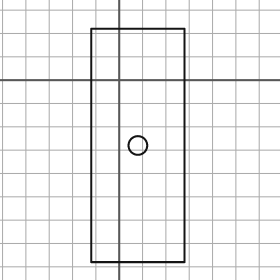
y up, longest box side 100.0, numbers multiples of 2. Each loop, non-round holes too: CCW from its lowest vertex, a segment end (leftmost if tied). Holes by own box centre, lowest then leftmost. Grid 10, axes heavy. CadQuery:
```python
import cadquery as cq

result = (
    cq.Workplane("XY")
    .moveTo(-12.0, -78.0)
    .lineTo(28.0, -78.0)
    .lineTo(28.0, 22.0)
    .lineTo(-12.0, 22.0)
    .close()
    .moveTo(8.0, -28.0)
    .circle(4.0)
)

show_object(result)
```